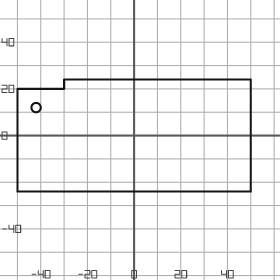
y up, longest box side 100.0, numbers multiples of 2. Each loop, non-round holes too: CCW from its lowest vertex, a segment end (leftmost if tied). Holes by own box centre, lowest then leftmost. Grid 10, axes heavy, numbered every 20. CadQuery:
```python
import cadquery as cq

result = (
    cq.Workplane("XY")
    .moveTo(-50.0, -24.0)
    .lineTo(50.0, -24.0)
    .lineTo(50.0, 24.0)
    .lineTo(-30.0, 24.0)
    .lineTo(-30.0, 20.0)
    .lineTo(-50.0, 20.0)
    .close()
    .moveTo(-42.0, 12.0)
    .circle(2.0)
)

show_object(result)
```